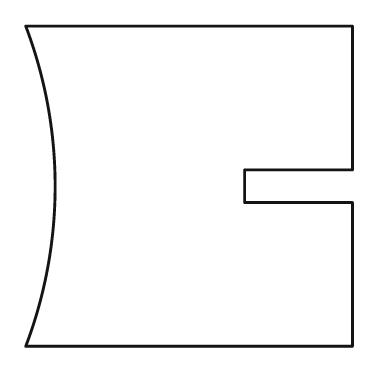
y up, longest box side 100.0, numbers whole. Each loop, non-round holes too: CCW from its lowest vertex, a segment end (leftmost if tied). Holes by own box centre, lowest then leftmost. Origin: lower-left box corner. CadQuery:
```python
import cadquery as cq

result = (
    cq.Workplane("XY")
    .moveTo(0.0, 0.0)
    .lineTo(100.0, 0.0)
    .lineTo(100.0, 44.0)
    .lineTo(67.0, 44.0)
    .lineTo(67.0, 54.0)
    .lineTo(100.0, 54.0)
    .lineTo(100.0, 98.0)
    .lineTo(0.0, 98.0)
    .threePointArc((9.0, 49.0), (0.0, 0.0))
    .close()
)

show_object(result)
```